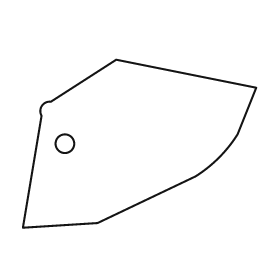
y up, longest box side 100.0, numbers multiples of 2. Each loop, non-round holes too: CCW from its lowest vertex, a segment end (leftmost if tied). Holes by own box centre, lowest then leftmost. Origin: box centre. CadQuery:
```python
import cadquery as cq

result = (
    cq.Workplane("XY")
    .moveTo(-50.0, -36.0)
    .lineTo(-18.0, -34.0)
    .lineTo(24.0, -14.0)
    .threePointArc((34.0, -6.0), (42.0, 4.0))
    .lineTo(50.0, 24.0)
    .lineTo(-10.0, 36.0)
    .lineTo(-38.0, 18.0)
    .threePointArc((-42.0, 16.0), (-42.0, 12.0))
    .close()
    .moveTo(-32.0, 0.0)
    .circle(4.0)
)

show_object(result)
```